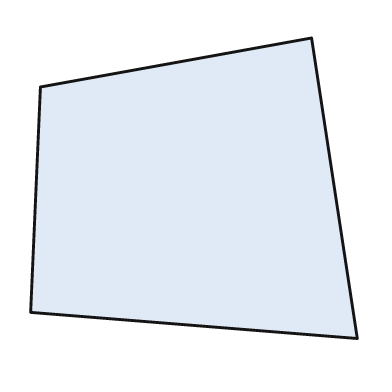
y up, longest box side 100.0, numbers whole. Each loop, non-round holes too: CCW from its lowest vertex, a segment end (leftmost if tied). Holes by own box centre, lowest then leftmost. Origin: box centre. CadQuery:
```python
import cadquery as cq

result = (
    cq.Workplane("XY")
    .moveTo(50.0, -46.0)
    .lineTo(36.0, 46.0)
    .lineTo(-47.0, 31.0)
    .lineTo(-50.0, -38.0)
    .close()
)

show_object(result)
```